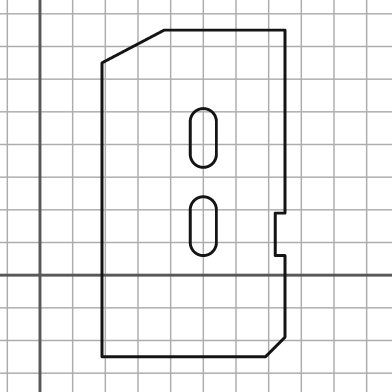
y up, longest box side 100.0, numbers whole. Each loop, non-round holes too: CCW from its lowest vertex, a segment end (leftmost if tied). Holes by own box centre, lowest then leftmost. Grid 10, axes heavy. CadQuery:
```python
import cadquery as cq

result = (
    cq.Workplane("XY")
    .moveTo(19.0, -25.0)
    .lineTo(69.0, -25.0)
    .lineTo(75.0, -19.0)
    .lineTo(75.0, 6.0)
    .lineTo(72.0, 6.0)
    .lineTo(72.0, 19.0)
    .lineTo(75.0, 19.0)
    .lineTo(75.0, 75.0)
    .lineTo(38.0, 75.0)
    .lineTo(19.0, 65.0)
    .close()
    .moveTo(46.0, 10.0)
    .threePointArc((50.0, 6.0), (54.0, 10.0))
    .lineTo(54.0, 20.0)
    .threePointArc((50.0, 24.0), (46.0, 20.0))
    .close()
    .moveTo(46.0, 37.0)
    .threePointArc((50.0, 33.0), (54.0, 37.0))
    .lineTo(54.0, 47.0)
    .threePointArc((50.0, 51.0), (46.0, 47.0))
    .close()
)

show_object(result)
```